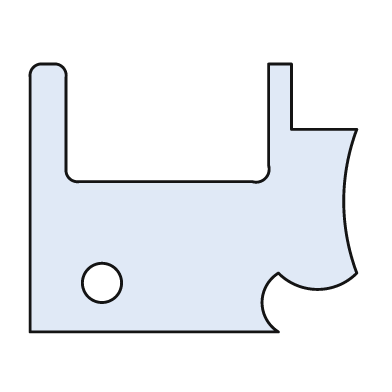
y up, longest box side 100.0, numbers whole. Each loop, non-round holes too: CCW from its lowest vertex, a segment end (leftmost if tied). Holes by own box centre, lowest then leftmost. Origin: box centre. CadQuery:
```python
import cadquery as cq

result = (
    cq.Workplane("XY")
    .moveTo(-50.0, -41.0)
    .lineTo(26.0, -41.0)
    .threePointArc((21.0, -32.0), (26.0, -23.0))
    .threePointArc((38.0, -28.0), (50.0, -23.0))
    .threePointArc((46.0, -1.0), (50.0, 21.0))
    .lineTo(30.0, 21.0)
    .lineTo(30.0, 41.0)
    .lineTo(23.0, 41.0)
    .lineTo(23.0, 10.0)
    .threePointArc((22.0, 6.0), (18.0, 5.0))
    .lineTo(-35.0, 5.0)
    .threePointArc((-38.0, 6.0), (-39.0, 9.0))
    .lineTo(-39.0, 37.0)
    .threePointArc((-40.0, 40.0), (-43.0, 41.0))
    .lineTo(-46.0, 41.0)
    .threePointArc((-49.0, 40.0), (-50.0, 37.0))
    .close()
    .moveTo(-28.0, -26.0)
    .circle(6.0)
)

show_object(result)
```